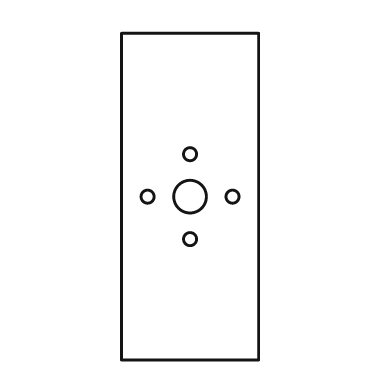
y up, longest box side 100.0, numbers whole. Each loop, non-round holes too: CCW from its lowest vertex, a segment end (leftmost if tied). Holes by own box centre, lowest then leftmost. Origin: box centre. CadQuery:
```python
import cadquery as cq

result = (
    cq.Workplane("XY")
    .moveTo(-21.0, -50.0)
    .lineTo(21.0, -50.0)
    .lineTo(21.0, 50.0)
    .lineTo(-21.0, 50.0)
    .close()
    .moveTo(0.0, -13.0)
    .circle(2.0)
    .moveTo(-13.0, 0.0)
    .circle(2.0)
    .moveTo(0.0, 0.0)
    .circle(5.0)
    .moveTo(13.0, 0.0)
    .circle(2.0)
    .moveTo(0.0, 13.0)
    .circle(2.0)
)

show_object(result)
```